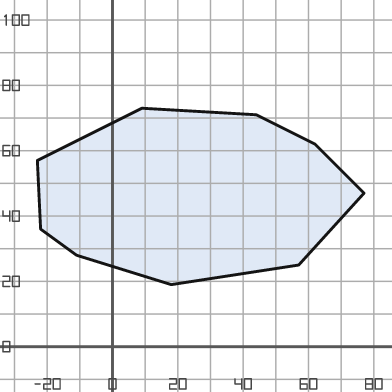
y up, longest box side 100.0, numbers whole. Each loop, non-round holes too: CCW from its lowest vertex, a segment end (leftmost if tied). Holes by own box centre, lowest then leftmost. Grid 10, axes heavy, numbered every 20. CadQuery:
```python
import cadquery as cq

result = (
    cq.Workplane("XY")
    .moveTo(18.0, 19.0)
    .lineTo(57.0, 25.0)
    .lineTo(77.0, 47.0)
    .lineTo(62.0, 62.0)
    .lineTo(44.0, 71.0)
    .lineTo(9.0, 73.0)
    .lineTo(-23.0, 57.0)
    .lineTo(-22.0, 36.0)
    .lineTo(-11.0, 28.0)
    .close()
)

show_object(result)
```